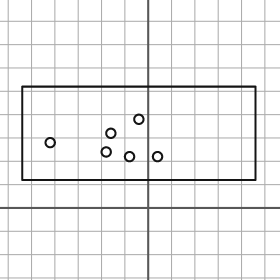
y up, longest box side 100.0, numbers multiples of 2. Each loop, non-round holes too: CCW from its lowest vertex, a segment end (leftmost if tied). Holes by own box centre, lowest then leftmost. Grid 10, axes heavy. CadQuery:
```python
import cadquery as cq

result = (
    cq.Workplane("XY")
    .moveTo(-54.0, 12.0)
    .lineTo(46.0, 12.0)
    .lineTo(46.0, 52.0)
    .lineTo(-54.0, 52.0)
    .close()
    .moveTo(-8.0, 22.0)
    .circle(2.0)
    .moveTo(4.0, 22.0)
    .circle(2.0)
    .moveTo(-18.0, 24.0)
    .circle(2.0)
    .moveTo(-42.0, 28.0)
    .circle(2.0)
    .moveTo(-16.0, 32.0)
    .circle(2.0)
    .moveTo(-4.0, 38.0)
    .circle(2.0)
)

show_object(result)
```